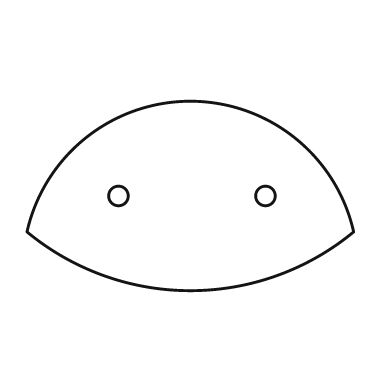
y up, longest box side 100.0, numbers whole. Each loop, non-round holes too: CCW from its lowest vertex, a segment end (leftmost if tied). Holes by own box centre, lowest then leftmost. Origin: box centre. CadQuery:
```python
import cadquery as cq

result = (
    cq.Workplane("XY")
    .moveTo(-50.0, -11.0)
    .threePointArc((0.0, -29.0), (50.0, -11.0))
    .threePointArc((0.0, 29.0), (-50.0, -11.0))
    .close()
    .moveTo(-22.0, 0.0)
    .circle(3.0)
    .moveTo(23.0, 0.0)
    .circle(3.0)
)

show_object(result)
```